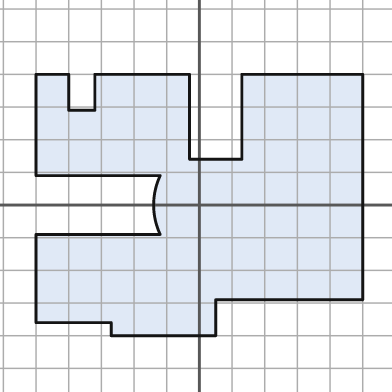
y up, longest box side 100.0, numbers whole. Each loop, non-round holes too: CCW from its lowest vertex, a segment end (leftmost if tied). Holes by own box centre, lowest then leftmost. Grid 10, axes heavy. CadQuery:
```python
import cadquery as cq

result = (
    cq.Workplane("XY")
    .moveTo(-27.0, -40.0)
    .lineTo(5.0, -40.0)
    .lineTo(5.0, -29.0)
    .lineTo(50.0, -29.0)
    .lineTo(50.0, 40.0)
    .lineTo(13.0, 40.0)
    .lineTo(13.0, 14.0)
    .lineTo(-3.0, 14.0)
    .lineTo(-3.0, 40.0)
    .lineTo(-32.0, 40.0)
    .lineTo(-32.0, 29.0)
    .lineTo(-40.0, 29.0)
    .lineTo(-40.0, 40.0)
    .lineTo(-50.0, 40.0)
    .lineTo(-50.0, 9.0)
    .lineTo(-12.0, 9.0)
    .threePointArc((-14.0, 0.0), (-12.0, -9.0))
    .lineTo(-50.0, -9.0)
    .lineTo(-50.0, -36.0)
    .lineTo(-27.0, -36.0)
    .close()
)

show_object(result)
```